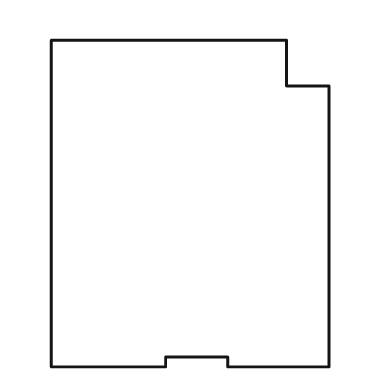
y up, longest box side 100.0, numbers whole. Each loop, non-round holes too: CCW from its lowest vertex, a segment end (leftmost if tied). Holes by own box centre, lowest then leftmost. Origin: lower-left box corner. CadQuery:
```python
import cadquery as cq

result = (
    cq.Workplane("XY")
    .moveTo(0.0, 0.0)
    .lineTo(35.0, 0.0)
    .lineTo(35.0, 3.0)
    .lineTo(54.0, 3.0)
    .lineTo(54.0, 0.0)
    .lineTo(85.0, 0.0)
    .lineTo(85.0, 86.0)
    .lineTo(72.0, 86.0)
    .lineTo(72.0, 100.0)
    .lineTo(0.0, 100.0)
    .close()
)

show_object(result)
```